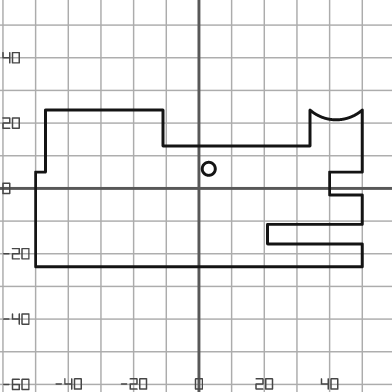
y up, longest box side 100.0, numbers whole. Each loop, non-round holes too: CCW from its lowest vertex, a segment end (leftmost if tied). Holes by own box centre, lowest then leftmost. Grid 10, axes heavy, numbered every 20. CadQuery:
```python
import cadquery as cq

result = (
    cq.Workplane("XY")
    .moveTo(-50.0, -24.0)
    .lineTo(50.0, -24.0)
    .lineTo(50.0, -17.0)
    .lineTo(21.0, -17.0)
    .lineTo(21.0, -11.0)
    .lineTo(50.0, -11.0)
    .lineTo(50.0, -2.0)
    .lineTo(40.0, -2.0)
    .lineTo(40.0, 5.0)
    .lineTo(50.0, 5.0)
    .lineTo(50.0, 24.0)
    .threePointArc((42.0, 21.0), (34.0, 24.0))
    .lineTo(34.0, 13.0)
    .lineTo(-11.0, 13.0)
    .lineTo(-11.0, 24.0)
    .lineTo(-47.0, 24.0)
    .lineTo(-47.0, 5.0)
    .lineTo(-50.0, 5.0)
    .close()
    .moveTo(3.0, 6.0)
    .circle(2.0)
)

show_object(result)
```